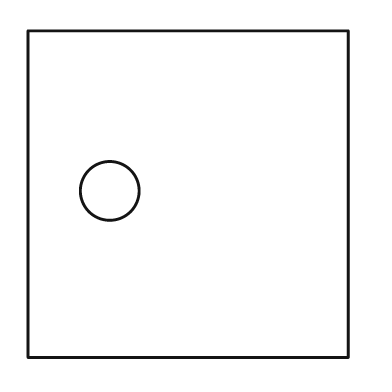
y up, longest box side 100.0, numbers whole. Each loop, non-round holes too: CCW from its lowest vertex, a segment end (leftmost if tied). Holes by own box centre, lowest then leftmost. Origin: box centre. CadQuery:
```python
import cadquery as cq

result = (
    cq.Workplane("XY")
    .moveTo(-49.0, -50.0)
    .lineTo(49.0, -50.0)
    .lineTo(49.0, 50.0)
    .lineTo(-49.0, 50.0)
    .close()
    .moveTo(-24.0, 1.0)
    .circle(9.0)
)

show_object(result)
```